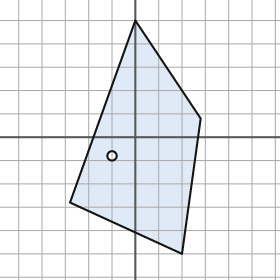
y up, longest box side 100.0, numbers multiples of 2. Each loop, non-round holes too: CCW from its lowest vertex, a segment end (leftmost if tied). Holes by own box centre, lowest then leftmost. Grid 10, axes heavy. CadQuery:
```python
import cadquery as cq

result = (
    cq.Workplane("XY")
    .moveTo(20.0, -50.0)
    .lineTo(28.0, 8.0)
    .lineTo(0.0, 50.0)
    .lineTo(-28.0, -28.0)
    .close()
    .moveTo(-10.0, -8.0)
    .circle(2.0)
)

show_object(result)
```